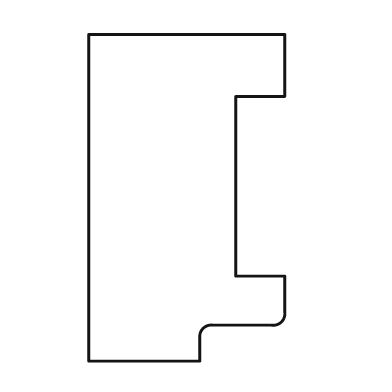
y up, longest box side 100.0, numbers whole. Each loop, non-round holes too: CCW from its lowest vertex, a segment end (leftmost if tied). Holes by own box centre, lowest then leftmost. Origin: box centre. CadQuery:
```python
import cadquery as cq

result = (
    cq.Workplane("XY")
    .moveTo(-30.0, -50.0)
    .lineTo(4.0, -50.0)
    .lineTo(4.0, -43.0)
    .threePointArc((5.0, -40.0), (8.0, -39.0))
    .lineTo(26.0, -39.0)
    .threePointArc((29.0, -38.0), (30.0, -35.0))
    .lineTo(30.0, -24.0)
    .lineTo(15.0, -24.0)
    .lineTo(15.0, 31.0)
    .lineTo(30.0, 31.0)
    .lineTo(30.0, 50.0)
    .lineTo(-30.0, 50.0)
    .close()
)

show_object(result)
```